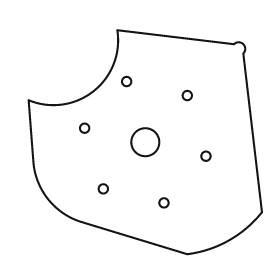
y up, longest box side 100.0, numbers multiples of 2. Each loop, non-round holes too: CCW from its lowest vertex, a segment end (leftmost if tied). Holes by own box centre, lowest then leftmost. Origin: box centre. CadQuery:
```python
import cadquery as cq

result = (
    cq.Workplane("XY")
    .moveTo(18.0, -48.0)
    .threePointArc((36.0, -42.0), (50.0, -30.0))
    .lineTo(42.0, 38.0)
    .threePointArc((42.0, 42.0), (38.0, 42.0))
    .lineTo(-12.0, 48.0)
    .threePointArc((-22.0, 22.0), (-50.0, 18.0))
    .lineTo(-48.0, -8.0)
    .threePointArc((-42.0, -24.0), (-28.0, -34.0))
    .close()
    .moveTo(8.0, -26.0)
    .circle(2.0)
    .moveTo(-18.0, -20.0)
    .circle(2.0)
    .moveTo(26.0, -6.0)
    .circle(2.0)
    .moveTo(0.0, 0.0)
    .circle(6.0)
    .moveTo(-26.0, 6.0)
    .circle(2.0)
    .moveTo(18.0, 20.0)
    .circle(2.0)
    .moveTo(-8.0, 26.0)
    .circle(2.0)
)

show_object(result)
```